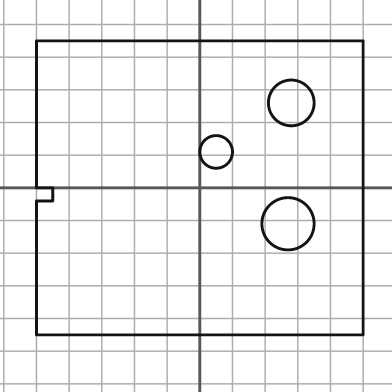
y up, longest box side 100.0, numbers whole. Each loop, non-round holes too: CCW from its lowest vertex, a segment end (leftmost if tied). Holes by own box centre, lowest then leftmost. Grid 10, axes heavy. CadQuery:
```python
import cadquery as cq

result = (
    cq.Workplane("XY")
    .moveTo(-50.0, -45.0)
    .lineTo(50.0, -45.0)
    .lineTo(50.0, 45.0)
    .lineTo(-50.0, 45.0)
    .lineTo(-50.0, 0.0)
    .lineTo(-45.0, 0.0)
    .lineTo(-45.0, -4.0)
    .lineTo(-50.0, -4.0)
    .close()
    .moveTo(27.0, -11.0)
    .circle(8.0)
    .moveTo(5.0, 11.0)
    .circle(5.0)
    .moveTo(28.0, 26.0)
    .circle(7.0)
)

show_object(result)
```